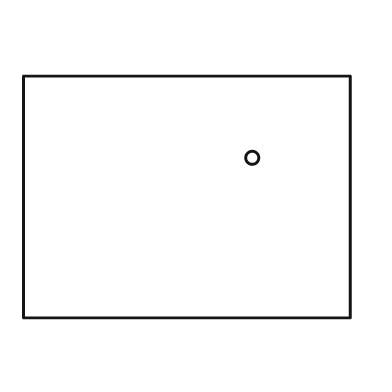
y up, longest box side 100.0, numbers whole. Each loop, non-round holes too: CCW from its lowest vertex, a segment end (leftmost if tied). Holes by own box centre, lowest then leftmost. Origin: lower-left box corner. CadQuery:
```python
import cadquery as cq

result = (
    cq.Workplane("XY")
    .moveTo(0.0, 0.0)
    .lineTo(100.0, 0.0)
    .lineTo(100.0, 74.0)
    .lineTo(0.0, 74.0)
    .close()
    .moveTo(70.0, 49.0)
    .circle(2.0)
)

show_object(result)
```